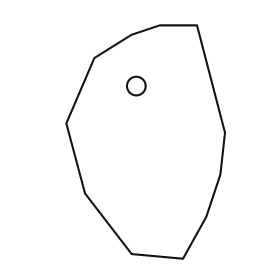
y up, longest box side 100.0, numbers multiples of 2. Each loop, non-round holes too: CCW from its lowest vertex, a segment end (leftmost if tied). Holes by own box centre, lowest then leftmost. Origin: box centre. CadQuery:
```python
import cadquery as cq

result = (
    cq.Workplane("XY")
    .moveTo(16.0, -50.0)
    .lineTo(26.0, -32.0)
    .lineTo(32.0, -14.0)
    .lineTo(34.0, 4.0)
    .lineTo(22.0, 50.0)
    .lineTo(6.0, 50.0)
    .lineTo(-6.0, 46.0)
    .lineTo(-22.0, 36.0)
    .lineTo(-34.0, 8.0)
    .lineTo(-26.0, -22.0)
    .lineTo(-6.0, -48.0)
    .close()
    .moveTo(-4.0, 24.0)
    .circle(4.0)
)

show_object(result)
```